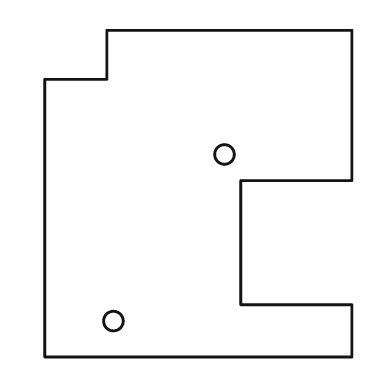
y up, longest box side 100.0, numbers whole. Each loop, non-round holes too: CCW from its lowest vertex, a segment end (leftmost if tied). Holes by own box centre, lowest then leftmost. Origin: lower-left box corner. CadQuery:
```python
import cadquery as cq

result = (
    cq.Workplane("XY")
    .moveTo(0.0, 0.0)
    .lineTo(94.0, 0.0)
    .lineTo(94.0, 16.0)
    .lineTo(60.0, 16.0)
    .lineTo(60.0, 54.0)
    .lineTo(94.0, 54.0)
    .lineTo(94.0, 100.0)
    .lineTo(19.0, 100.0)
    .lineTo(19.0, 85.0)
    .lineTo(0.0, 85.0)
    .close()
    .moveTo(21.0, 11.0)
    .circle(3.0)
    .moveTo(55.0, 62.0)
    .circle(3.0)
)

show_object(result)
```